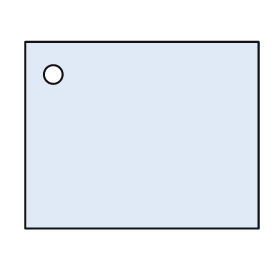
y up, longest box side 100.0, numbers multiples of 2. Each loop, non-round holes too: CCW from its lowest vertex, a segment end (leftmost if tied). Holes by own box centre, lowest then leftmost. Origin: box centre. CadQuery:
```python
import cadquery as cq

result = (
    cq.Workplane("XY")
    .moveTo(-50.0, -40.0)
    .lineTo(50.0, -40.0)
    .lineTo(50.0, 40.0)
    .lineTo(-50.0, 40.0)
    .close()
    .moveTo(-38.0, 26.0)
    .circle(4.0)
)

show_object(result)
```